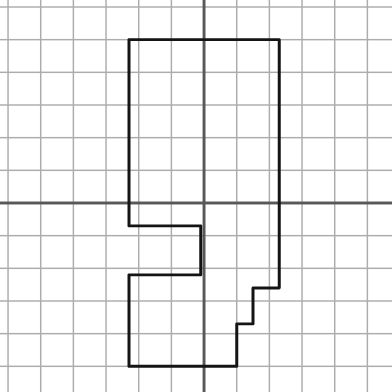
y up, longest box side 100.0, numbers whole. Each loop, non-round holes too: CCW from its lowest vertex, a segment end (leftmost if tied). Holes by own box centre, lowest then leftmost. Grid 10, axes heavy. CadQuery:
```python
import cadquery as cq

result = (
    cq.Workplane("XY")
    .moveTo(-23.0, -50.0)
    .lineTo(10.0, -50.0)
    .lineTo(10.0, -37.0)
    .lineTo(15.0, -37.0)
    .lineTo(15.0, -26.0)
    .lineTo(23.0, -26.0)
    .lineTo(23.0, 50.0)
    .lineTo(-23.0, 50.0)
    .lineTo(-23.0, -7.0)
    .lineTo(-1.0, -7.0)
    .lineTo(-1.0, -22.0)
    .lineTo(-23.0, -22.0)
    .close()
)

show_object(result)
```